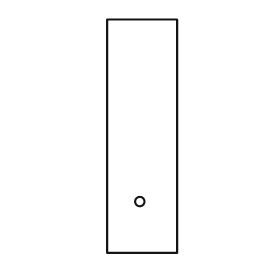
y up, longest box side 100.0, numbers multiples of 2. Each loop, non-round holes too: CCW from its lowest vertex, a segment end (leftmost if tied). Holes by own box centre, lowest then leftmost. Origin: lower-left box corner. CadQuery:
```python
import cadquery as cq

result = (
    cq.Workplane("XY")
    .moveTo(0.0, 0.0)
    .lineTo(30.0, 0.0)
    .lineTo(30.0, 100.0)
    .lineTo(0.0, 100.0)
    .close()
    .moveTo(14.0, 22.0)
    .circle(2.0)
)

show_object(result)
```